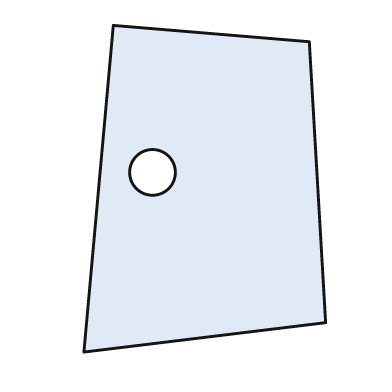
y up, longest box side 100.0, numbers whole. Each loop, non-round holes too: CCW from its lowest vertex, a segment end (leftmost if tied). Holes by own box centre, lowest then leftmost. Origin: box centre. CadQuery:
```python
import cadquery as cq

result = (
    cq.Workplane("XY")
    .moveTo(-37.0, -50.0)
    .lineTo(37.0, -41.0)
    .lineTo(32.0, 45.0)
    .lineTo(-28.0, 50.0)
    .close()
    .moveTo(-16.0, 5.0)
    .circle(7.0)
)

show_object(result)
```